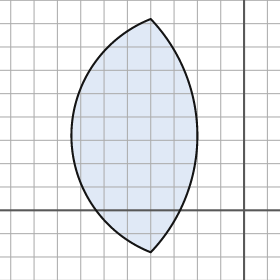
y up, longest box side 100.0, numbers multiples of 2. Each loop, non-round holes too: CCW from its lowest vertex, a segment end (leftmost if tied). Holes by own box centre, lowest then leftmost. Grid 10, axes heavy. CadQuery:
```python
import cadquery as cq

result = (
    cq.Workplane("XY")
    .moveTo(-40.0, -18.0)
    .threePointArc((-20.0, 32.0), (-40.0, 82.0))
    .threePointArc((-74.0, 32.0), (-40.0, -18.0))
    .close()
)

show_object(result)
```